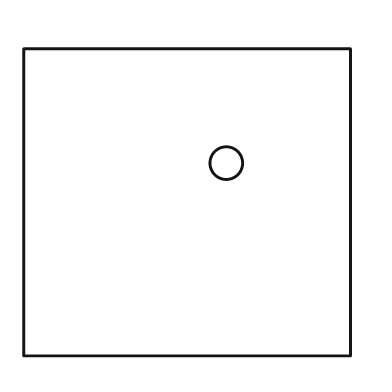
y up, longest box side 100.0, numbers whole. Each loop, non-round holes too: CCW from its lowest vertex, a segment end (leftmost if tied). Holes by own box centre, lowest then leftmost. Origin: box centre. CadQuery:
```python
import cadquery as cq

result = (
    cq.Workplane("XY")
    .moveTo(-50.0, -47.0)
    .lineTo(50.0, -47.0)
    .lineTo(50.0, 47.0)
    .lineTo(-50.0, 47.0)
    .close()
    .moveTo(12.0, 12.0)
    .circle(5.0)
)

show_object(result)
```